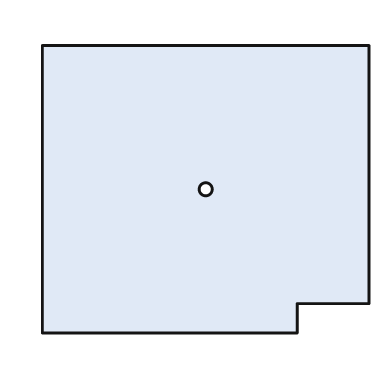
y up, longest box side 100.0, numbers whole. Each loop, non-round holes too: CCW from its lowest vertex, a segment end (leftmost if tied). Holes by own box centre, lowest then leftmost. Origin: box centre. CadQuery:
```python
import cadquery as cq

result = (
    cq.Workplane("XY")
    .moveTo(-50.0, -44.0)
    .lineTo(28.0, -44.0)
    .lineTo(28.0, -35.0)
    .lineTo(50.0, -35.0)
    .lineTo(50.0, 44.0)
    .lineTo(-50.0, 44.0)
    .close()
    .moveTo(0.0, 0.0)
    .circle(2.0)
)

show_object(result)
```